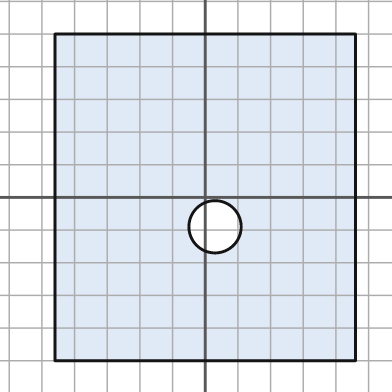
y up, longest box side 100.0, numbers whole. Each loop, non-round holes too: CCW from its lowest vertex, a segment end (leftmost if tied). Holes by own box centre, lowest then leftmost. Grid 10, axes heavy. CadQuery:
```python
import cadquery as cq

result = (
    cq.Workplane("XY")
    .moveTo(-46.0, -50.0)
    .lineTo(46.0, -50.0)
    .lineTo(46.0, 50.0)
    .lineTo(-46.0, 50.0)
    .close()
    .moveTo(3.0, -9.0)
    .circle(8.0)
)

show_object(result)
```